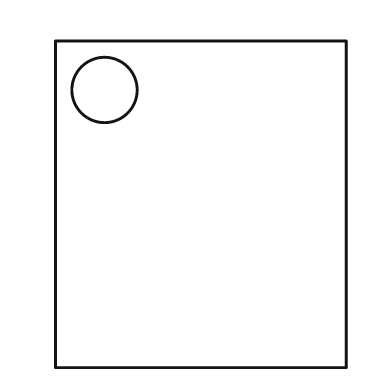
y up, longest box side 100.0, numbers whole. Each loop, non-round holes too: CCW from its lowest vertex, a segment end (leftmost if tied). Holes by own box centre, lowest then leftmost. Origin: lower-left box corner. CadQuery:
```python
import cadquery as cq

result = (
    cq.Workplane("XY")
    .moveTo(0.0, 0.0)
    .lineTo(89.0, 0.0)
    .lineTo(89.0, 100.0)
    .lineTo(0.0, 100.0)
    .close()
    .moveTo(15.0, 85.0)
    .circle(10.0)
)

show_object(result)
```